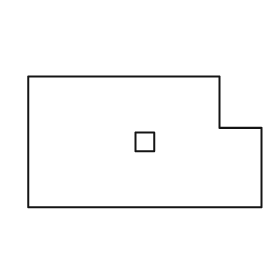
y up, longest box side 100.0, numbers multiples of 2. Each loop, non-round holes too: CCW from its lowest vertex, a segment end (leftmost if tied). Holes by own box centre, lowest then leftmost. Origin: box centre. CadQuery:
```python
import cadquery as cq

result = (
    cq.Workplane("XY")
    .moveTo(-50.0, -28.0)
    .lineTo(50.0, -28.0)
    .lineTo(50.0, 6.0)
    .lineTo(32.0, 6.0)
    .lineTo(32.0, 28.0)
    .lineTo(-50.0, 28.0)
    .close()
    .moveTo(-4.0, -4.0)
    .lineTo(4.0, -4.0)
    .lineTo(4.0, 4.0)
    .lineTo(-4.0, 4.0)
    .close()
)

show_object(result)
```